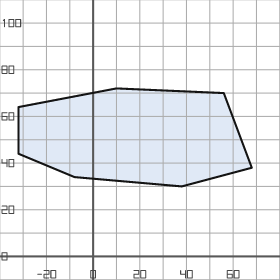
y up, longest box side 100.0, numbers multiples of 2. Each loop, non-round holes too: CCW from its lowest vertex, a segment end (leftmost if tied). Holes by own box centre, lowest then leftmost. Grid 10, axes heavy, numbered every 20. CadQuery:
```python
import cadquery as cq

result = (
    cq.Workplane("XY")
    .moveTo(38.0, 30.0)
    .lineTo(68.0, 38.0)
    .lineTo(56.0, 70.0)
    .lineTo(10.0, 72.0)
    .lineTo(-32.0, 64.0)
    .lineTo(-32.0, 44.0)
    .lineTo(-8.0, 34.0)
    .close()
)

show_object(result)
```